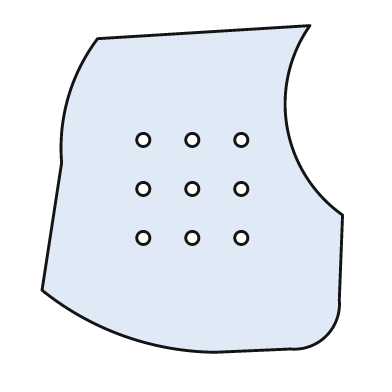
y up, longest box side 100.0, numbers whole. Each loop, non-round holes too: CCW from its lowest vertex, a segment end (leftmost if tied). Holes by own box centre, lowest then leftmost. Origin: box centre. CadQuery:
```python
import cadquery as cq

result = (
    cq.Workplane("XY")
    .moveTo(7.0, -50.0)
    .lineTo(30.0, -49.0)
    .threePointArc((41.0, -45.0), (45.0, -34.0))
    .lineTo(46.0, -8.0)
    .threePointArc((29.0, 19.0), (36.0, 50.0))
    .lineTo(-29.0, 46.0)
    .threePointArc((-38.0, 28.0), (-40.0, 8.0))
    .lineTo(-46.0, -31.0)
    .threePointArc((-21.0, -45.0), (7.0, -50.0))
    .close()
    .moveTo(-15.0, -15.0)
    .circle(2.0)
    .moveTo(0.0, -15.0)
    .circle(2.0)
    .moveTo(15.0, -15.0)
    .circle(2.0)
    .moveTo(-15.0, 0.0)
    .circle(2.0)
    .moveTo(0.0, 0.0)
    .circle(2.0)
    .moveTo(15.0, 0.0)
    .circle(2.0)
    .moveTo(-15.0, 15.0)
    .circle(2.0)
    .moveTo(0.0, 15.0)
    .circle(2.0)
    .moveTo(15.0, 15.0)
    .circle(2.0)
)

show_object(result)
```